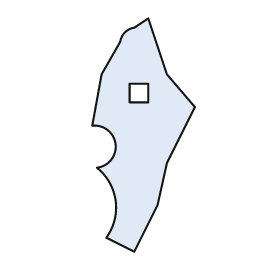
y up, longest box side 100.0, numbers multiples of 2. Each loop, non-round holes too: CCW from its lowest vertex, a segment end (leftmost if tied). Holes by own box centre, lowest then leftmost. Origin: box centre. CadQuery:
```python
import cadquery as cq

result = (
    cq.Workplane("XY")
    .moveTo(-4.0, -50.0)
    .lineTo(6.0, -30.0)
    .lineTo(10.0, -12.0)
    .lineTo(22.0, 12.0)
    .lineTo(10.0, 26.0)
    .lineTo(2.0, 50.0)
    .lineTo(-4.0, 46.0)
    .threePointArc((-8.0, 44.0), (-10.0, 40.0))
    .lineTo(-18.0, 26.0)
    .lineTo(-22.0, 4.0)
    .threePointArc((-12.0, -4.0), (-20.0, -14.0))
    .threePointArc((-12.0, -28.0), (-16.0, -44.0))
    .close()
    .moveTo(-6.0, 14.0)
    .lineTo(2.0, 14.0)
    .lineTo(2.0, 22.0)
    .lineTo(-6.0, 22.0)
    .close()
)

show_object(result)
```